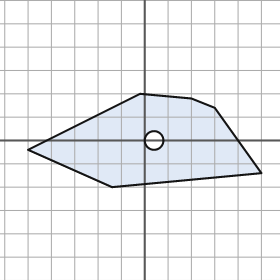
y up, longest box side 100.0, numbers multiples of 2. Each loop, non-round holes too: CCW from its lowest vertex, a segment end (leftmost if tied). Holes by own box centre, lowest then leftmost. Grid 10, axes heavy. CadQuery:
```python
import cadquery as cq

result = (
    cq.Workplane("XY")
    .moveTo(-14.0, -20.0)
    .lineTo(50.0, -14.0)
    .lineTo(30.0, 14.0)
    .lineTo(20.0, 18.0)
    .lineTo(-2.0, 20.0)
    .lineTo(-50.0, -4.0)
    .close()
    .moveTo(4.0, 0.0)
    .circle(4.0)
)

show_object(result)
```